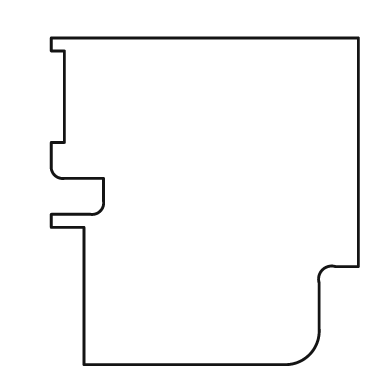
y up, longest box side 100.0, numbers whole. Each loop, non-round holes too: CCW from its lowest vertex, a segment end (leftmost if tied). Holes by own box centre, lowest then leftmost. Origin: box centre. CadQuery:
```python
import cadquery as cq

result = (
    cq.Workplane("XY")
    .moveTo(-37.0, -50.0)
    .lineTo(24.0, -50.0)
    .threePointArc((32.0, -47.0), (35.0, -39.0))
    .lineTo(35.0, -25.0)
    .threePointArc((36.0, -21.0), (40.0, -20.0))
    .lineTo(47.0, -20.0)
    .lineTo(47.0, 50.0)
    .lineTo(-47.0, 50.0)
    .lineTo(-47.0, 46.0)
    .lineTo(-43.0, 46.0)
    .lineTo(-43.0, 18.0)
    .lineTo(-47.0, 18.0)
    .lineTo(-47.0, 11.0)
    .threePointArc((-46.0, 8.0), (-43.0, 7.0))
    .lineTo(-31.0, 7.0)
    .lineTo(-31.0, 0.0)
    .threePointArc((-32.0, -3.0), (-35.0, -4.0))
    .lineTo(-47.0, -4.0)
    .lineTo(-47.0, -8.0)
    .lineTo(-37.0, -8.0)
    .close()
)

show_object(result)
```